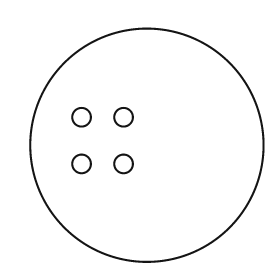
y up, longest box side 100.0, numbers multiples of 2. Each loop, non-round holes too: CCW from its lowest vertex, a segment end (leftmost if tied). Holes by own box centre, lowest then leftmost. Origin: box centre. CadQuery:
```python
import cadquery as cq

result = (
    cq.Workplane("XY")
    .moveTo(0.0, 0.0)
    .circle(50.0)
    .moveTo(-28.0, -8.0)
    .circle(4.0)
    .moveTo(-10.0, -8.0)
    .circle(4.0)
    .moveTo(-28.0, 12.0)
    .circle(4.0)
    .moveTo(-10.0, 12.0)
    .circle(4.0)
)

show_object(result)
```